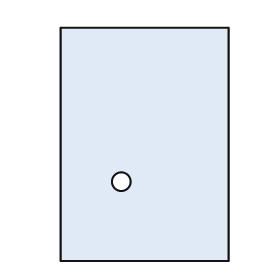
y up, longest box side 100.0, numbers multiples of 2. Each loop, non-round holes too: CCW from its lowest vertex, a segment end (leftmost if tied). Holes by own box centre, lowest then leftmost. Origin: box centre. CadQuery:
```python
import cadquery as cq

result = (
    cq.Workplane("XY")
    .moveTo(-36.0, -50.0)
    .lineTo(36.0, -50.0)
    .lineTo(36.0, 50.0)
    .lineTo(-36.0, 50.0)
    .close()
    .moveTo(-10.0, -16.0)
    .circle(4.0)
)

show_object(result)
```